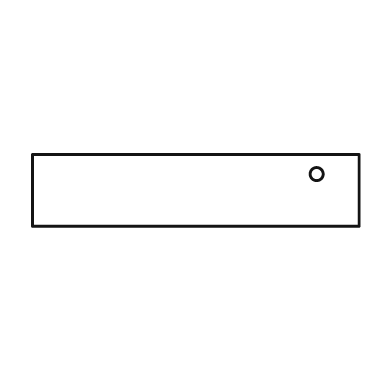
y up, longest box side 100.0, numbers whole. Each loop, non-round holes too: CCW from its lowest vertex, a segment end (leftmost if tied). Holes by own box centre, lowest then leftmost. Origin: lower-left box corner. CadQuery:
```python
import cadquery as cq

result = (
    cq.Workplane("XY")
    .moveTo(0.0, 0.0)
    .lineTo(100.0, 0.0)
    .lineTo(100.0, 22.0)
    .lineTo(0.0, 22.0)
    .close()
    .moveTo(87.0, 16.0)
    .circle(2.0)
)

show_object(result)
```